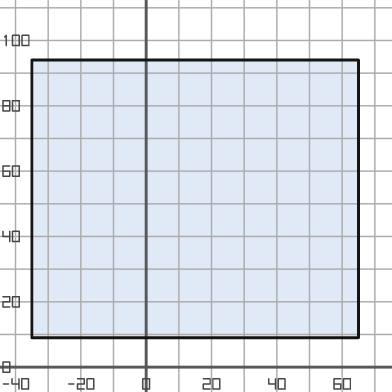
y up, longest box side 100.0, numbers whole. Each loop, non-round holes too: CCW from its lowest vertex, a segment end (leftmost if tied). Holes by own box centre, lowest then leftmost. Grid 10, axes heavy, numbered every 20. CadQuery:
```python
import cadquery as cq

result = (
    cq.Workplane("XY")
    .moveTo(-35.0, 9.0)
    .lineTo(65.0, 9.0)
    .lineTo(65.0, 94.0)
    .lineTo(-35.0, 94.0)
    .close()
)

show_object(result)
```